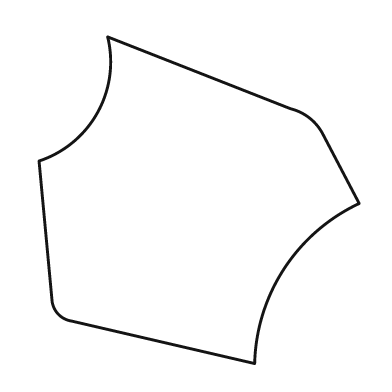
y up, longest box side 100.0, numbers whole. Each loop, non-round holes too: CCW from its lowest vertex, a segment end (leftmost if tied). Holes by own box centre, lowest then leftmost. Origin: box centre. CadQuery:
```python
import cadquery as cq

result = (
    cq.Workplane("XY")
    .moveTo(17.0, -50.0)
    .threePointArc((26.0, -21.0), (49.0, -1.0))
    .lineTo(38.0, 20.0)
    .threePointArc((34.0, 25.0), (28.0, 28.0))
    .lineTo(-28.0, 50.0)
    .threePointArc((-31.0, 27.0), (-49.0, 12.0))
    .lineTo(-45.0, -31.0)
    .threePointArc((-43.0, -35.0), (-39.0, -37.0))
    .close()
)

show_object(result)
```